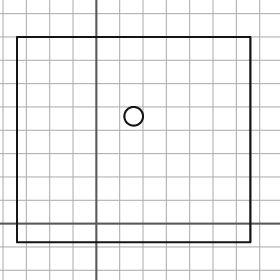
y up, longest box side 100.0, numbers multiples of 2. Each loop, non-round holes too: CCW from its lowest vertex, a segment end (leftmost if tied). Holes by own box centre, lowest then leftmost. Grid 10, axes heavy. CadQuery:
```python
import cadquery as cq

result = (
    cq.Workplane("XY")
    .moveTo(-34.0, -8.0)
    .lineTo(66.0, -8.0)
    .lineTo(66.0, 80.0)
    .lineTo(-34.0, 80.0)
    .close()
    .moveTo(16.0, 46.0)
    .circle(4.0)
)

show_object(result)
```